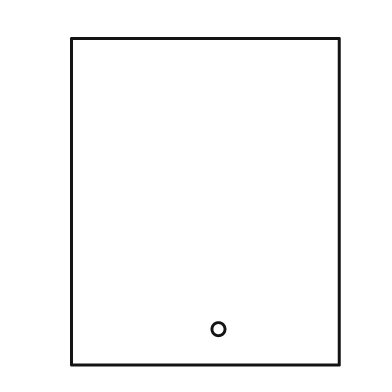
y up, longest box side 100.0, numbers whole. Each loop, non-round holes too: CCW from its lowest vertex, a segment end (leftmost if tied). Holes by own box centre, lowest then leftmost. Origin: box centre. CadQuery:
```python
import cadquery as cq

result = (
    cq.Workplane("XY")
    .moveTo(-41.0, -50.0)
    .lineTo(41.0, -50.0)
    .lineTo(41.0, 50.0)
    .lineTo(-41.0, 50.0)
    .close()
    .moveTo(4.0, -39.0)
    .circle(2.0)
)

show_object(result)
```